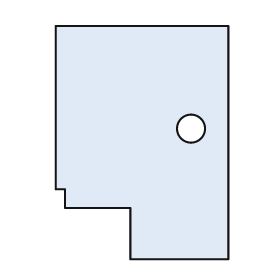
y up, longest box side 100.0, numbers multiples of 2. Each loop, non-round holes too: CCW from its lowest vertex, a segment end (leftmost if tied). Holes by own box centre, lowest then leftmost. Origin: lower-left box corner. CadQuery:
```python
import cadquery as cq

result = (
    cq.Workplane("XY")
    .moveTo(32.0, 0.0)
    .lineTo(74.0, 0.0)
    .lineTo(74.0, 100.0)
    .lineTo(0.0, 100.0)
    .lineTo(0.0, 30.0)
    .lineTo(4.0, 30.0)
    .lineTo(4.0, 22.0)
    .lineTo(32.0, 22.0)
    .close()
    .moveTo(58.0, 56.0)
    .circle(6.0)
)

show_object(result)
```